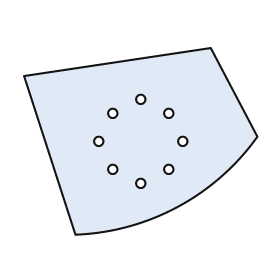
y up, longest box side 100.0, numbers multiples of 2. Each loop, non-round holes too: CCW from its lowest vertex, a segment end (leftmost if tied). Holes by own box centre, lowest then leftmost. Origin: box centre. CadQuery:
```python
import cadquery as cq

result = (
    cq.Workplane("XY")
    .moveTo(-28.0, -40.0)
    .threePointArc((16.0, -28.0), (50.0, 2.0))
    .lineTo(30.0, 40.0)
    .lineTo(-50.0, 28.0)
    .close()
    .moveTo(0.0, -18.0)
    .circle(2.0)
    .moveTo(-12.0, -12.0)
    .circle(2.0)
    .moveTo(12.0, -12.0)
    .circle(2.0)
    .moveTo(-18.0, 0.0)
    .circle(2.0)
    .moveTo(18.0, 0.0)
    .circle(2.0)
    .moveTo(-12.0, 12.0)
    .circle(2.0)
    .moveTo(12.0, 12.0)
    .circle(2.0)
    .moveTo(0.0, 18.0)
    .circle(2.0)
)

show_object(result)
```